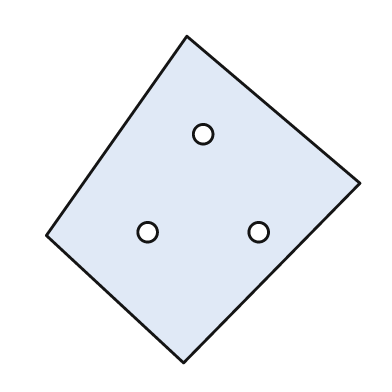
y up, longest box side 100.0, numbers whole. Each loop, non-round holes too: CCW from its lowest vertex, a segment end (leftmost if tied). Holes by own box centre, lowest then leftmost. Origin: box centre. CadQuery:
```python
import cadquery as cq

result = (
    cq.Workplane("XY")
    .moveTo(-6.0, -50.0)
    .lineTo(48.0, 5.0)
    .lineTo(-5.0, 50.0)
    .lineTo(-48.0, -11.0)
    .close()
    .moveTo(-17.0, -10.0)
    .circle(3.0)
    .moveTo(17.0, -10.0)
    .circle(3.0)
    .moveTo(0.0, 20.0)
    .circle(3.0)
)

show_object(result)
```